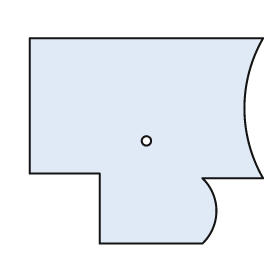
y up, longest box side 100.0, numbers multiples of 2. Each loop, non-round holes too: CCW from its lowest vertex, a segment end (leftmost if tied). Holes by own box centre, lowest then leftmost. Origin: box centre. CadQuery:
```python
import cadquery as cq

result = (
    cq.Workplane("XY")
    .moveTo(-20.0, -44.0)
    .lineTo(24.0, -44.0)
    .threePointArc((30.0, -30.0), (24.0, -16.0))
    .lineTo(50.0, -16.0)
    .threePointArc((42.0, 14.0), (50.0, 44.0))
    .lineTo(-50.0, 44.0)
    .lineTo(-50.0, -14.0)
    .lineTo(-20.0, -14.0)
    .close()
    .moveTo(0.0, 0.0)
    .circle(2.0)
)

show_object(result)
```